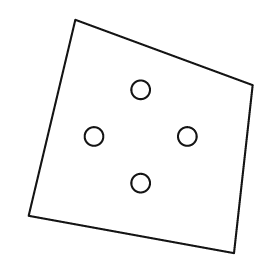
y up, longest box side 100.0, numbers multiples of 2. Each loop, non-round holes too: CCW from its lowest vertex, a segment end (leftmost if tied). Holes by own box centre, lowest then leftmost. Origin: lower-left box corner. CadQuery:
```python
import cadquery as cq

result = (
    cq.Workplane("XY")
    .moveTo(88.0, 0.0)
    .lineTo(96.0, 72.0)
    .lineTo(20.0, 100.0)
    .lineTo(0.0, 16.0)
    .close()
    .moveTo(48.0, 30.0)
    .circle(4.0)
    .moveTo(28.0, 50.0)
    .circle(4.0)
    .moveTo(68.0, 50.0)
    .circle(4.0)
    .moveTo(48.0, 70.0)
    .circle(4.0)
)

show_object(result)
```